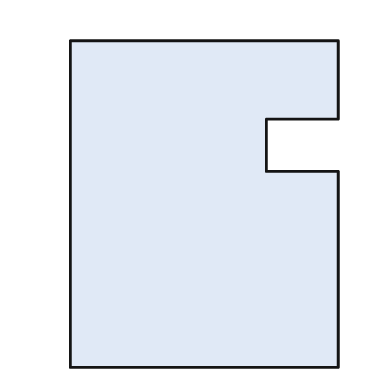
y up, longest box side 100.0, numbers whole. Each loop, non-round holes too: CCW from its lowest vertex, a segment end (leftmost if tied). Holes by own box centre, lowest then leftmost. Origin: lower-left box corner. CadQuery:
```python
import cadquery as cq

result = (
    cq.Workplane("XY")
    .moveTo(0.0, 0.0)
    .lineTo(82.0, 0.0)
    .lineTo(82.0, 60.0)
    .lineTo(60.0, 60.0)
    .lineTo(60.0, 76.0)
    .lineTo(82.0, 76.0)
    .lineTo(82.0, 100.0)
    .lineTo(0.0, 100.0)
    .close()
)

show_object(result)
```